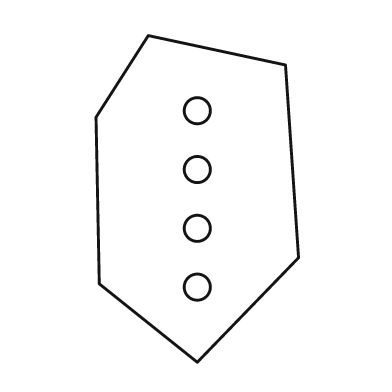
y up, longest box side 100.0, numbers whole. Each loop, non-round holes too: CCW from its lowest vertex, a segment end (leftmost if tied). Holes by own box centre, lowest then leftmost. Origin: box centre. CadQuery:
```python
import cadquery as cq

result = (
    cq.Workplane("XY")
    .moveTo(0.0, -50.0)
    .lineTo(31.0, -18.0)
    .lineTo(27.0, 41.0)
    .lineTo(-15.0, 50.0)
    .lineTo(-31.0, 25.0)
    .lineTo(-30.0, -26.0)
    .close()
    .moveTo(0.0, -27.0)
    .circle(4.0)
    .moveTo(0.0, -9.0)
    .circle(4.0)
    .moveTo(0.0, 9.0)
    .circle(4.0)
    .moveTo(0.0, 27.0)
    .circle(4.0)
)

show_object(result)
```